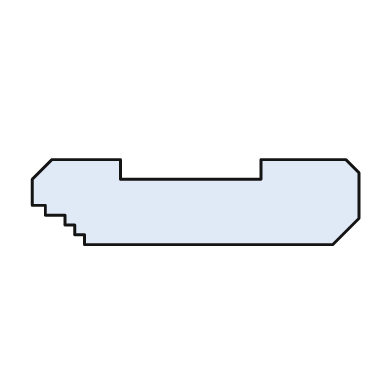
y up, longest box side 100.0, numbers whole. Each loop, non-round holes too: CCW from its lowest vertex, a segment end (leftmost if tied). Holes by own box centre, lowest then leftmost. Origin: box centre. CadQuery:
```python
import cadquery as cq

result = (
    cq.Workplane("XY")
    .moveTo(-34.0, -13.0)
    .lineTo(42.0, -13.0)
    .lineTo(50.0, -5.0)
    .lineTo(50.0, 9.0)
    .lineTo(46.0, 13.0)
    .lineTo(20.0, 13.0)
    .lineTo(20.0, 7.0)
    .lineTo(-23.0, 7.0)
    .lineTo(-23.0, 13.0)
    .lineTo(-44.0, 13.0)
    .lineTo(-50.0, 7.0)
    .lineTo(-50.0, -1.0)
    .lineTo(-46.0, -1.0)
    .lineTo(-46.0, -4.0)
    .lineTo(-40.0, -4.0)
    .lineTo(-40.0, -7.0)
    .lineTo(-37.0, -7.0)
    .lineTo(-37.0, -10.0)
    .lineTo(-34.0, -10.0)
    .close()
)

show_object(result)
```